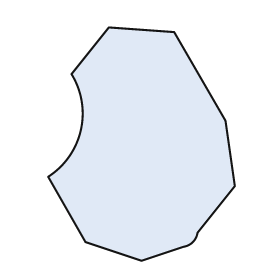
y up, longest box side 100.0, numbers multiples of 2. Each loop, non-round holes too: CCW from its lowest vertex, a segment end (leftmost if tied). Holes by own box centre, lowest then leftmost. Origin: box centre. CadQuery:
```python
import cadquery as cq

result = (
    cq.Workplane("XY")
    .moveTo(0.0, -50.0)
    .lineTo(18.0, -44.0)
    .threePointArc((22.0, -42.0), (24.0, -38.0))
    .lineTo(40.0, -18.0)
    .lineTo(36.0, 10.0)
    .lineTo(14.0, 48.0)
    .lineTo(-14.0, 50.0)
    .lineTo(-30.0, 30.0)
    .threePointArc((-26.0, 6.0), (-40.0, -14.0))
    .lineTo(-24.0, -42.0)
    .close()
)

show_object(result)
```